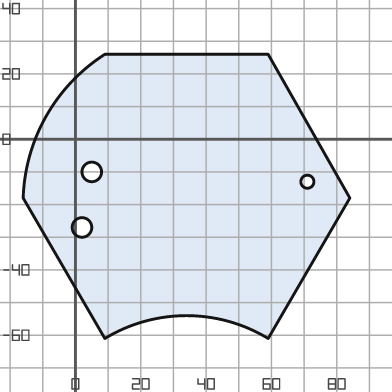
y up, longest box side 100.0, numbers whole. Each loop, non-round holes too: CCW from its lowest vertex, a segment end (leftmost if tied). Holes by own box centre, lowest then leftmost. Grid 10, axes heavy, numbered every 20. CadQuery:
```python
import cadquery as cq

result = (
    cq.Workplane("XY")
    .moveTo(9.0, -61.0)
    .threePointArc((34.0, -54.0), (59.0, -61.0))
    .lineTo(84.0, -18.0)
    .lineTo(59.0, 26.0)
    .lineTo(9.0, 26.0)
    .threePointArc((-9.0, 7.0), (-16.0, -18.0))
    .close()
    .moveTo(2.0, -27.0)
    .circle(3.0)
    .moveTo(71.0, -13.0)
    .circle(2.0)
    .moveTo(5.0, -10.0)
    .circle(3.0)
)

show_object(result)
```